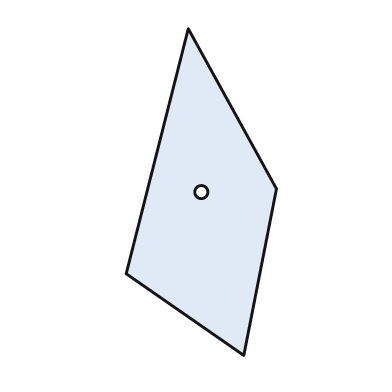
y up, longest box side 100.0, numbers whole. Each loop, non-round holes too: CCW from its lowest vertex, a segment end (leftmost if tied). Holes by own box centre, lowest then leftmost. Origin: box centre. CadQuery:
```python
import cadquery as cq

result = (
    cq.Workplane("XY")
    .moveTo(13.0, -50.0)
    .lineTo(23.0, 1.0)
    .lineTo(-4.0, 50.0)
    .lineTo(-23.0, -25.0)
    .close()
    .moveTo(0.0, 0.0)
    .circle(2.0)
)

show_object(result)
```